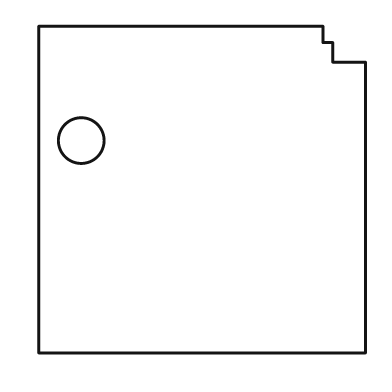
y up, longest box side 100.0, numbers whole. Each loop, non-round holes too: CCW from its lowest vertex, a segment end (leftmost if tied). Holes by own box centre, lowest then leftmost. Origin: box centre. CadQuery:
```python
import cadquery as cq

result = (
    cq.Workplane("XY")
    .moveTo(-50.0, -50.0)
    .lineTo(50.0, -50.0)
    .lineTo(50.0, 39.0)
    .lineTo(40.0, 39.0)
    .lineTo(40.0, 45.0)
    .lineTo(37.0, 45.0)
    .lineTo(37.0, 50.0)
    .lineTo(-50.0, 50.0)
    .close()
    .moveTo(-37.0, 15.0)
    .circle(7.0)
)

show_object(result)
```